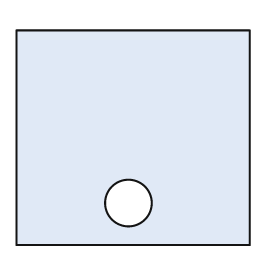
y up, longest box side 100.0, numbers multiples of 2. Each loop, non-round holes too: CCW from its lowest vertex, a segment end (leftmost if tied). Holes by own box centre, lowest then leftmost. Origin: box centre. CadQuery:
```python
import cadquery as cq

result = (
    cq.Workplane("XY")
    .moveTo(-50.0, -46.0)
    .lineTo(50.0, -46.0)
    .lineTo(50.0, 46.0)
    .lineTo(-50.0, 46.0)
    .close()
    .moveTo(-2.0, -28.0)
    .circle(10.0)
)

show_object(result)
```